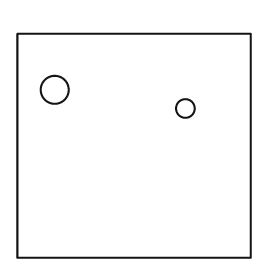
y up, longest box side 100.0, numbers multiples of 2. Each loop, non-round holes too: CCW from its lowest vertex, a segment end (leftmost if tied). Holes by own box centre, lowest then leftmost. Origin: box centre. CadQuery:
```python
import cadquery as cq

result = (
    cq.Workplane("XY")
    .moveTo(-50.0, -48.0)
    .lineTo(50.0, -48.0)
    .lineTo(50.0, 48.0)
    .lineTo(-50.0, 48.0)
    .close()
    .moveTo(22.0, 16.0)
    .circle(4.0)
    .moveTo(-34.0, 24.0)
    .circle(6.0)
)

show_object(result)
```